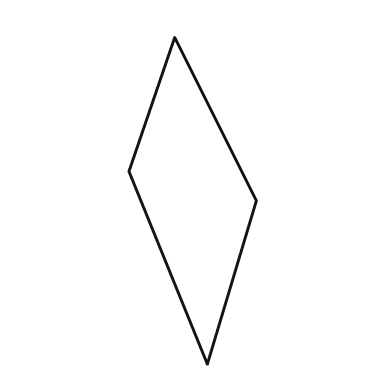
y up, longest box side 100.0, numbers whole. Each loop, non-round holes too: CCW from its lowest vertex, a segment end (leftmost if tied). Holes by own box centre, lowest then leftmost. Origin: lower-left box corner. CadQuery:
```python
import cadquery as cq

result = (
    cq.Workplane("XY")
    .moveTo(24.0, 0.0)
    .lineTo(39.0, 50.0)
    .lineTo(14.0, 100.0)
    .lineTo(0.0, 59.0)
    .close()
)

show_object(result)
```